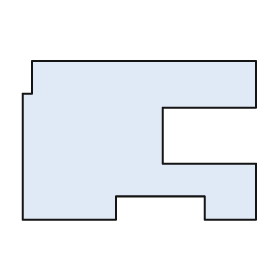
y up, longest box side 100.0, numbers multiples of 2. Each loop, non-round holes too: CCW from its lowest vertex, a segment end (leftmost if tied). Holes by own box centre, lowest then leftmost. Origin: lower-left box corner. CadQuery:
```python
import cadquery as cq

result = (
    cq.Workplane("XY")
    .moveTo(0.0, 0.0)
    .lineTo(40.0, 0.0)
    .lineTo(40.0, 10.0)
    .lineTo(78.0, 10.0)
    .lineTo(78.0, 0.0)
    .lineTo(100.0, 0.0)
    .lineTo(100.0, 24.0)
    .lineTo(60.0, 24.0)
    .lineTo(60.0, 48.0)
    .lineTo(100.0, 48.0)
    .lineTo(100.0, 68.0)
    .lineTo(4.0, 68.0)
    .lineTo(4.0, 54.0)
    .lineTo(0.0, 54.0)
    .close()
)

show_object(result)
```